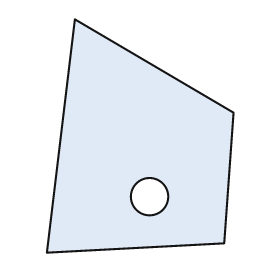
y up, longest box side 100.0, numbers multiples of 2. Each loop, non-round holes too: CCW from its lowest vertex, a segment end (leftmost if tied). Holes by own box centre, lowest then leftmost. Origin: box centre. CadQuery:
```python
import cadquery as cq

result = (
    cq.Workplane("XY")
    .moveTo(-40.0, -50.0)
    .lineTo(36.0, -46.0)
    .lineTo(40.0, 10.0)
    .lineTo(-28.0, 50.0)
    .close()
    .moveTo(4.0, -26.0)
    .circle(8.0)
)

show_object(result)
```